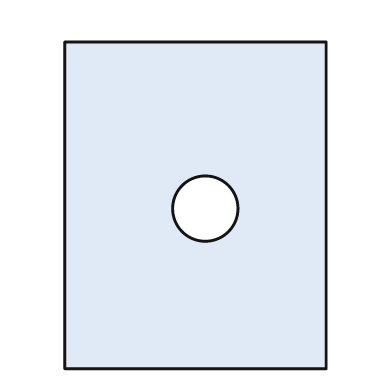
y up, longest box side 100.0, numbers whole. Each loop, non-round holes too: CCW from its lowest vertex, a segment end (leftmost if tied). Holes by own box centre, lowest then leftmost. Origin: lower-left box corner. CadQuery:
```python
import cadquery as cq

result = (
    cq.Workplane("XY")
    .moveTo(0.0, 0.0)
    .lineTo(80.0, 0.0)
    .lineTo(80.0, 100.0)
    .lineTo(0.0, 100.0)
    .close()
    .moveTo(43.0, 49.0)
    .circle(10.0)
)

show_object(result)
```